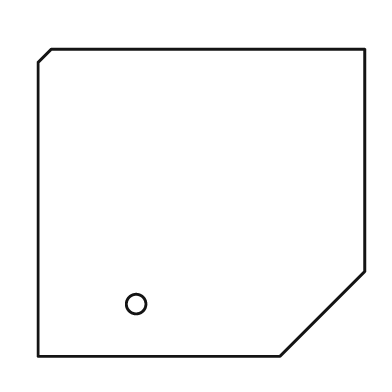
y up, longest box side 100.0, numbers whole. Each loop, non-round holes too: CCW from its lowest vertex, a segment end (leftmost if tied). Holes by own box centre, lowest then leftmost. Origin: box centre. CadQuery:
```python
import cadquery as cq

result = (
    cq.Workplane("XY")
    .moveTo(-50.0, -47.0)
    .lineTo(24.0, -47.0)
    .lineTo(50.0, -21.0)
    .lineTo(50.0, 47.0)
    .lineTo(-46.0, 47.0)
    .lineTo(-50.0, 43.0)
    .close()
    .moveTo(-20.0, -31.0)
    .circle(3.0)
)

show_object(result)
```